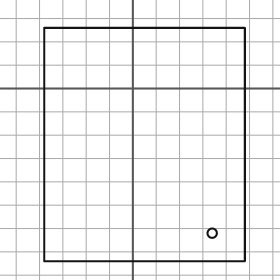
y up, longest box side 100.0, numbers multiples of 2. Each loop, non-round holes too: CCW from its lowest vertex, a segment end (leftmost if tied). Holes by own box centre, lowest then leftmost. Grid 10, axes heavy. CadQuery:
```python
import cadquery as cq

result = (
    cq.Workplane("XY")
    .moveTo(-38.0, -74.0)
    .lineTo(48.0, -74.0)
    .lineTo(48.0, 26.0)
    .lineTo(-38.0, 26.0)
    .close()
    .moveTo(34.0, -62.0)
    .circle(2.0)
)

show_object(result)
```